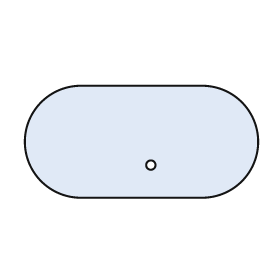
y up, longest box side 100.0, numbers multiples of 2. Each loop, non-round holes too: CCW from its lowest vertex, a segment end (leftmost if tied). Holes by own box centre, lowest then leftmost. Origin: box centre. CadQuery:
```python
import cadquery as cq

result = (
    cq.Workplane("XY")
    .moveTo(-26.0, -24.0)
    .lineTo(26.0, -24.0)
    .threePointArc((50.0, 0.0), (26.0, 24.0))
    .lineTo(-26.0, 24.0)
    .threePointArc((-50.0, 0.0), (-26.0, -24.0))
    .close()
    .moveTo(4.0, -10.0)
    .circle(2.0)
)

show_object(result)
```